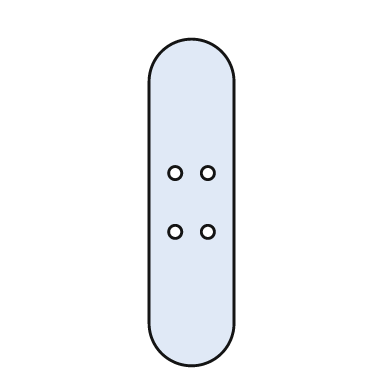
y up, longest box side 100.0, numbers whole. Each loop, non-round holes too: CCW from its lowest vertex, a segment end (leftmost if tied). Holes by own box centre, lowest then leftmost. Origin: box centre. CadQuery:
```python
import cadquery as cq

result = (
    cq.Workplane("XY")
    .moveTo(-13.0, -37.0)
    .threePointArc((0.0, -50.0), (13.0, -37.0))
    .lineTo(13.0, 37.0)
    .threePointArc((0.0, 50.0), (-13.0, 37.0))
    .close()
    .moveTo(-5.0, -9.0)
    .circle(2.0)
    .moveTo(5.0, -9.0)
    .circle(2.0)
    .moveTo(-5.0, 9.0)
    .circle(2.0)
    .moveTo(5.0, 9.0)
    .circle(2.0)
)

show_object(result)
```